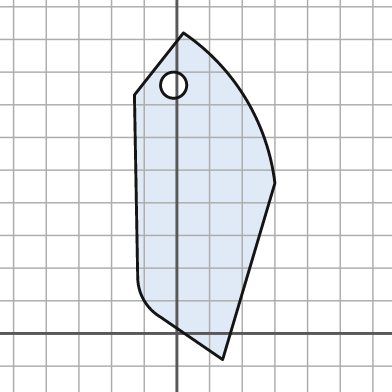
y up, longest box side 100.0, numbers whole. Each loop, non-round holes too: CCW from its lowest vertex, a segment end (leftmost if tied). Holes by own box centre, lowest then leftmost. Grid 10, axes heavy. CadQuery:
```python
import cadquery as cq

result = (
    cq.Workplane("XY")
    .moveTo(14.0, -8.0)
    .lineTo(30.0, 46.0)
    .threePointArc((21.0, 72.0), (2.0, 92.0))
    .lineTo(-13.0, 73.0)
    .lineTo(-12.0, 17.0)
    .threePointArc((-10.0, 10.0), (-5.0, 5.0))
    .close()
    .moveTo(-1.0, 76.0)
    .circle(4.0)
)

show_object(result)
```